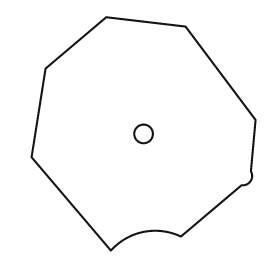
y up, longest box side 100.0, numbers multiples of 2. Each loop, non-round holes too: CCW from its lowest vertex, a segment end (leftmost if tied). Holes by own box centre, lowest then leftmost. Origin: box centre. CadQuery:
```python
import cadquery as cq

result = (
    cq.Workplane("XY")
    .moveTo(-14.0, -50.0)
    .threePointArc((0.0, -42.0), (16.0, -44.0))
    .lineTo(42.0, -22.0)
    .threePointArc((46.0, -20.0), (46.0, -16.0))
    .lineTo(48.0, 6.0)
    .lineTo(18.0, 46.0)
    .lineTo(-16.0, 50.0)
    .lineTo(-42.0, 28.0)
    .lineTo(-48.0, -10.0)
    .close()
    .moveTo(0.0, 0.0)
    .circle(4.0)
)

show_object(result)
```